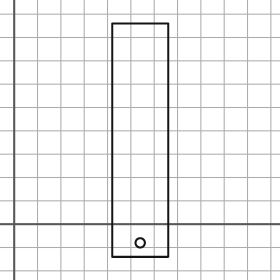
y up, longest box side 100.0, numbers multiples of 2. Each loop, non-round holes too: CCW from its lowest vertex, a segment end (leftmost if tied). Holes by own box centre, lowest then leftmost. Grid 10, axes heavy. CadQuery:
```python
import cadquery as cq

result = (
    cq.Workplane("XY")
    .moveTo(42.0, -14.0)
    .lineTo(66.0, -14.0)
    .lineTo(66.0, 86.0)
    .lineTo(42.0, 86.0)
    .close()
    .moveTo(54.0, -8.0)
    .circle(2.0)
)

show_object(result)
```